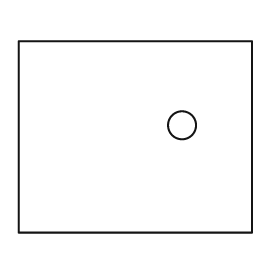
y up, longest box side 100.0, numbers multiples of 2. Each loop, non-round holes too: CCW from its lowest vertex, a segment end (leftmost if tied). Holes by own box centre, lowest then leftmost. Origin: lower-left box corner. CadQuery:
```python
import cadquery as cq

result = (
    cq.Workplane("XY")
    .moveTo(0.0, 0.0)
    .lineTo(100.0, 0.0)
    .lineTo(100.0, 82.0)
    .lineTo(0.0, 82.0)
    .close()
    .moveTo(70.0, 46.0)
    .circle(6.0)
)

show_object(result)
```